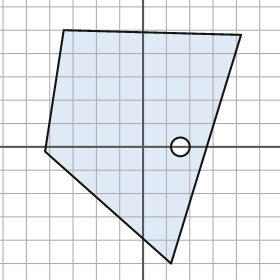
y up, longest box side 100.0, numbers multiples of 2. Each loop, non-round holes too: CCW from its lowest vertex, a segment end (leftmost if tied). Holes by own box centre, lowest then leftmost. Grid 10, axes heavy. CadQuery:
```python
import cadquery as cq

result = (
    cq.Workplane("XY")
    .moveTo(12.0, -50.0)
    .lineTo(42.0, 48.0)
    .lineTo(-34.0, 50.0)
    .lineTo(-42.0, -2.0)
    .close()
    .moveTo(16.0, 0.0)
    .circle(4.0)
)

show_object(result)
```